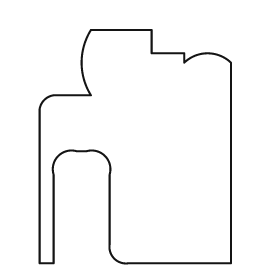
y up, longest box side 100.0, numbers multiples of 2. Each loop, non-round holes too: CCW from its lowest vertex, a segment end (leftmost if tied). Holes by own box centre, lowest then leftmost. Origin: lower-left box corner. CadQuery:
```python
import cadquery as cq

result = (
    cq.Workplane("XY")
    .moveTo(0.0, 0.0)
    .lineTo(6.0, 0.0)
    .lineTo(6.0, 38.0)
    .threePointArc((8.0, 46.0), (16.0, 48.0))
    .lineTo(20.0, 48.0)
    .threePointArc((28.0, 46.0), (30.0, 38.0))
    .lineTo(30.0, 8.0)
    .threePointArc((32.0, 2.0), (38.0, 0.0))
    .lineTo(82.0, 0.0)
    .lineTo(82.0, 86.0)
    .threePointArc((72.0, 90.0), (62.0, 86.0))
    .lineTo(62.0, 90.0)
    .lineTo(48.0, 90.0)
    .lineTo(48.0, 100.0)
    .lineTo(22.0, 100.0)
    .threePointArc((18.0, 86.0), (22.0, 72.0))
    .lineTo(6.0, 72.0)
    .threePointArc((2.0, 70.0), (0.0, 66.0))
    .close()
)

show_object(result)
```